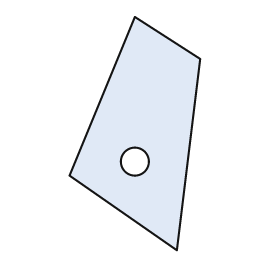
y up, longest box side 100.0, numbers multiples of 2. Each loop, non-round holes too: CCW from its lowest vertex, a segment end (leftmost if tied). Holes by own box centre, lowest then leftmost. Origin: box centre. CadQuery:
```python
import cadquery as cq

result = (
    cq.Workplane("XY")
    .moveTo(18.0, -50.0)
    .lineTo(28.0, 32.0)
    .lineTo(0.0, 50.0)
    .lineTo(-28.0, -18.0)
    .close()
    .moveTo(0.0, -12.0)
    .circle(6.0)
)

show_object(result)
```